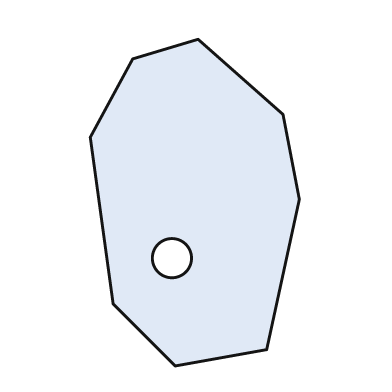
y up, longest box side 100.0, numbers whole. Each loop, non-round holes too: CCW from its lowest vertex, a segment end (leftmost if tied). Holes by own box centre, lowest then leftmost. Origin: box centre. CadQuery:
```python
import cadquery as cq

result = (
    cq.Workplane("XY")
    .moveTo(-6.0, -50.0)
    .lineTo(22.0, -45.0)
    .lineTo(32.0, 1.0)
    .lineTo(27.0, 27.0)
    .lineTo(1.0, 50.0)
    .lineTo(-19.0, 44.0)
    .lineTo(-32.0, 20.0)
    .lineTo(-25.0, -31.0)
    .close()
    .moveTo(-7.0, -17.0)
    .circle(6.0)
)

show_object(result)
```